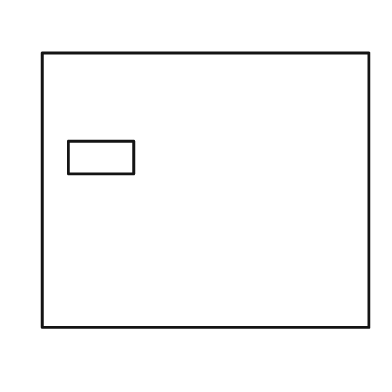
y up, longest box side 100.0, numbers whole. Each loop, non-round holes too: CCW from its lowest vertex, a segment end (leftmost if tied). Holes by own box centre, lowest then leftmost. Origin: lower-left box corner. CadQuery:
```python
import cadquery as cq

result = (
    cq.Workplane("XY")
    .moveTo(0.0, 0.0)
    .lineTo(100.0, 0.0)
    .lineTo(100.0, 84.0)
    .lineTo(0.0, 84.0)
    .close()
    .moveTo(8.0, 47.0)
    .lineTo(28.0, 47.0)
    .lineTo(28.0, 57.0)
    .lineTo(8.0, 57.0)
    .close()
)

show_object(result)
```